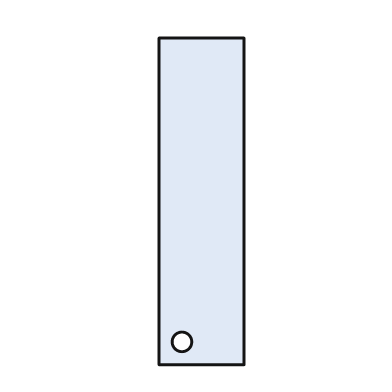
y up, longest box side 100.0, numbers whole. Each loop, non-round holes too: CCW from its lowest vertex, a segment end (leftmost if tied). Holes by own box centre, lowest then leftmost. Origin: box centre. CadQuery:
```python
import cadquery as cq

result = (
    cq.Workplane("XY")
    .moveTo(-13.0, -50.0)
    .lineTo(13.0, -50.0)
    .lineTo(13.0, 50.0)
    .lineTo(-13.0, 50.0)
    .close()
    .moveTo(-6.0, -43.0)
    .circle(3.0)
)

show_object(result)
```